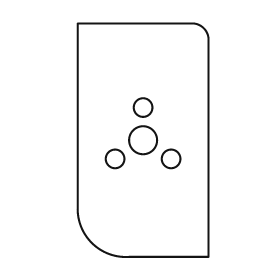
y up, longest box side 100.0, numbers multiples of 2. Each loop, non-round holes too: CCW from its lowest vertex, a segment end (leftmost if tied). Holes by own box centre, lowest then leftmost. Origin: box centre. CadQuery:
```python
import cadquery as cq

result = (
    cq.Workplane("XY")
    .moveTo(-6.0, -50.0)
    .lineTo(28.0, -50.0)
    .lineTo(28.0, 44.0)
    .threePointArc((26.0, 48.0), (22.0, 50.0))
    .lineTo(-28.0, 50.0)
    .lineTo(-28.0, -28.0)
    .threePointArc((-22.0, -44.0), (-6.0, -50.0))
    .close()
    .moveTo(-12.0, -8.0)
    .circle(4.0)
    .moveTo(12.0, -8.0)
    .circle(4.0)
    .moveTo(0.0, 0.0)
    .circle(6.0)
    .moveTo(0.0, 14.0)
    .circle(4.0)
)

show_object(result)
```